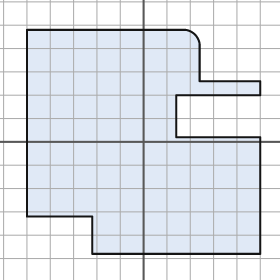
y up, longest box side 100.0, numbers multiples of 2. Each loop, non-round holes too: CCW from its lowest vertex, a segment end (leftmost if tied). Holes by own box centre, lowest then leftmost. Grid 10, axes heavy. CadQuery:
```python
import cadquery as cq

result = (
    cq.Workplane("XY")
    .moveTo(-22.0, -48.0)
    .lineTo(50.0, -48.0)
    .lineTo(50.0, 2.0)
    .lineTo(14.0, 2.0)
    .lineTo(14.0, 20.0)
    .lineTo(50.0, 20.0)
    .lineTo(50.0, 26.0)
    .lineTo(24.0, 26.0)
    .lineTo(24.0, 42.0)
    .threePointArc((22.0, 46.0), (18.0, 48.0))
    .lineTo(-50.0, 48.0)
    .lineTo(-50.0, -32.0)
    .lineTo(-22.0, -32.0)
    .close()
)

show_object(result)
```